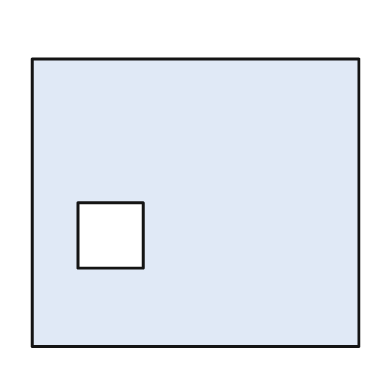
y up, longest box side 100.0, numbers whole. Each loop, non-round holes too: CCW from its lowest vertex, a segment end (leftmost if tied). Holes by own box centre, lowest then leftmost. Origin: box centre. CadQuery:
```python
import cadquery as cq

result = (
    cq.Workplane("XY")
    .moveTo(-50.0, -44.0)
    .lineTo(50.0, -44.0)
    .lineTo(50.0, 44.0)
    .lineTo(-50.0, 44.0)
    .close()
    .moveTo(-36.0, -20.0)
    .lineTo(-16.0, -20.0)
    .lineTo(-16.0, 0.0)
    .lineTo(-36.0, 0.0)
    .close()
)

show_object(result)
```